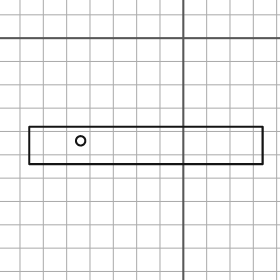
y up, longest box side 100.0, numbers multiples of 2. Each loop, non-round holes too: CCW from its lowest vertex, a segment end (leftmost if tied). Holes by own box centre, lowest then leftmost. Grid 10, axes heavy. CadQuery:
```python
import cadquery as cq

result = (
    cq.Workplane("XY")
    .moveTo(-66.0, -54.0)
    .lineTo(34.0, -54.0)
    .lineTo(34.0, -38.0)
    .lineTo(-66.0, -38.0)
    .close()
    .moveTo(-44.0, -44.0)
    .circle(2.0)
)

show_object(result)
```